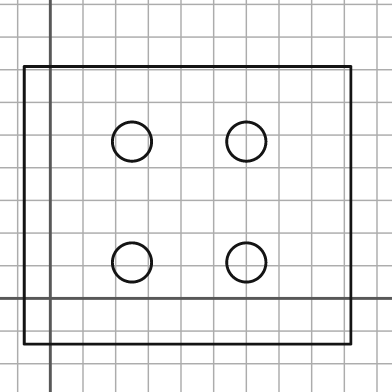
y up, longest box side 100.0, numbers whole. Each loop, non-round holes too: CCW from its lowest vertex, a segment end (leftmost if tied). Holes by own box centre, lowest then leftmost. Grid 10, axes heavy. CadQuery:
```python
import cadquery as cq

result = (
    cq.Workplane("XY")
    .moveTo(-8.0, -14.0)
    .lineTo(92.0, -14.0)
    .lineTo(92.0, 71.0)
    .lineTo(-8.0, 71.0)
    .close()
    .moveTo(25.0, 11.0)
    .circle(6.0)
    .moveTo(60.0, 11.0)
    .circle(6.0)
    .moveTo(25.0, 48.0)
    .circle(6.0)
    .moveTo(60.0, 48.0)
    .circle(6.0)
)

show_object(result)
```